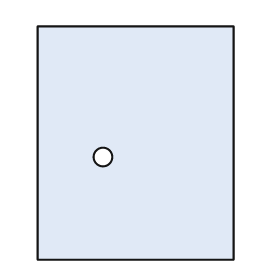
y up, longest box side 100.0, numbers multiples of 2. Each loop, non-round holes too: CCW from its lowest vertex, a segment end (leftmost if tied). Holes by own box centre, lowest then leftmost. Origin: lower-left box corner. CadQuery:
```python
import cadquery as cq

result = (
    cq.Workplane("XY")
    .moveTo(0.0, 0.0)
    .lineTo(84.0, 0.0)
    .lineTo(84.0, 100.0)
    .lineTo(0.0, 100.0)
    .close()
    .moveTo(28.0, 44.0)
    .circle(4.0)
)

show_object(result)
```